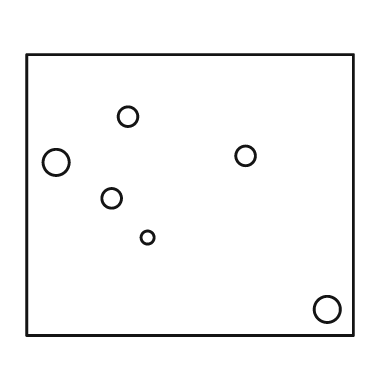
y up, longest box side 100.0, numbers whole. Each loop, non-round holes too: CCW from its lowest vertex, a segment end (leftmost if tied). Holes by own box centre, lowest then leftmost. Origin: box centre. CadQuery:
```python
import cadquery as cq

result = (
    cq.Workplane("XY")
    .moveTo(-50.0, -43.0)
    .lineTo(50.0, -43.0)
    .lineTo(50.0, 43.0)
    .lineTo(-50.0, 43.0)
    .close()
    .moveTo(42.0, -35.0)
    .circle(4.0)
    .moveTo(-13.0, -13.0)
    .circle(2.0)
    .moveTo(-24.0, -1.0)
    .circle(3.0)
    .moveTo(-41.0, 10.0)
    .circle(4.0)
    .moveTo(17.0, 12.0)
    .circle(3.0)
    .moveTo(-19.0, 24.0)
    .circle(3.0)
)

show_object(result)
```